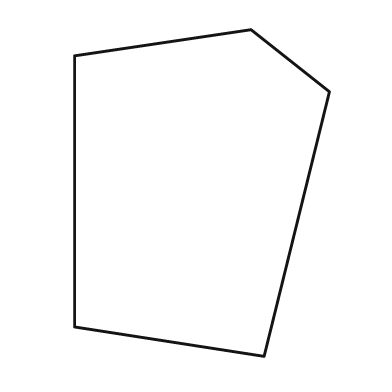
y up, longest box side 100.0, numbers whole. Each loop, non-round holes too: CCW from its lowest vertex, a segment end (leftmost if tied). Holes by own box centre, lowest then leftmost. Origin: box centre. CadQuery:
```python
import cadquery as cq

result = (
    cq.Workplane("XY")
    .moveTo(19.0, -50.0)
    .lineTo(39.0, 31.0)
    .lineTo(15.0, 50.0)
    .lineTo(-39.0, 42.0)
    .lineTo(-39.0, -41.0)
    .close()
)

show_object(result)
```